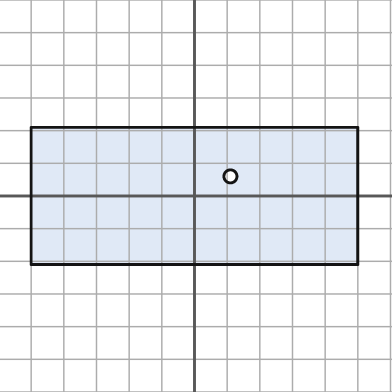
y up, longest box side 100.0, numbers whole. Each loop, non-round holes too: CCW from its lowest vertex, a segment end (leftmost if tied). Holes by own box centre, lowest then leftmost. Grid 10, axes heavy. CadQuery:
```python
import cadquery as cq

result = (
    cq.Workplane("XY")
    .moveTo(-50.0, -21.0)
    .lineTo(50.0, -21.0)
    .lineTo(50.0, 21.0)
    .lineTo(-50.0, 21.0)
    .close()
    .moveTo(11.0, 6.0)
    .circle(2.0)
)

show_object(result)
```